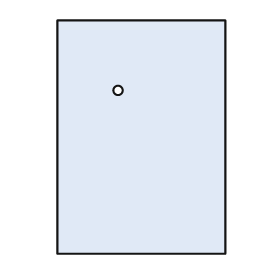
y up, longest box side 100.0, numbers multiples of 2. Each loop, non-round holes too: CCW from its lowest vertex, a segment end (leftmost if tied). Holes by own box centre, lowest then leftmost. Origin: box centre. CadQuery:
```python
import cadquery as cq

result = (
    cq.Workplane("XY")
    .moveTo(-36.0, -50.0)
    .lineTo(36.0, -50.0)
    .lineTo(36.0, 50.0)
    .lineTo(-36.0, 50.0)
    .close()
    .moveTo(-10.0, 20.0)
    .circle(2.0)
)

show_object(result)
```